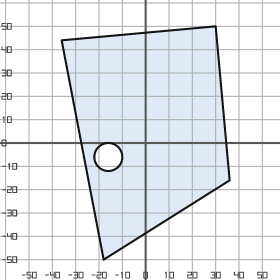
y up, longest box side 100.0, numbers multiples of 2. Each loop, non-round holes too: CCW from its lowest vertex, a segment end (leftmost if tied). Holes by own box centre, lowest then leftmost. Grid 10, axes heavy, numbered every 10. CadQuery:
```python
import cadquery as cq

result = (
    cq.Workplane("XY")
    .moveTo(-18.0, -50.0)
    .lineTo(36.0, -16.0)
    .lineTo(30.0, 50.0)
    .lineTo(-36.0, 44.0)
    .close()
    .moveTo(-16.0, -6.0)
    .circle(6.0)
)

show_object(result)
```